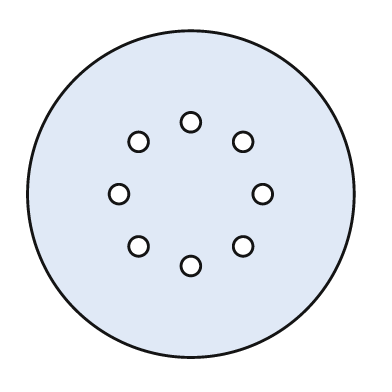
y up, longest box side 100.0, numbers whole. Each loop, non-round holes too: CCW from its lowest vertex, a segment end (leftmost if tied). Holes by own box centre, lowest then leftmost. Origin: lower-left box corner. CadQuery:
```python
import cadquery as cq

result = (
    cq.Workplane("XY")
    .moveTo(50.0, 50.0)
    .circle(50.0)
    .moveTo(50.0, 28.0)
    .circle(3.0)
    .moveTo(34.0, 34.0)
    .circle(3.0)
    .moveTo(66.0, 34.0)
    .circle(3.0)
    .moveTo(28.0, 50.0)
    .circle(3.0)
    .moveTo(72.0, 50.0)
    .circle(3.0)
    .moveTo(34.0, 66.0)
    .circle(3.0)
    .moveTo(66.0, 66.0)
    .circle(3.0)
    .moveTo(50.0, 72.0)
    .circle(3.0)
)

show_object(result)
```